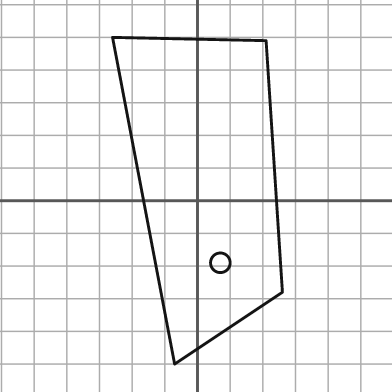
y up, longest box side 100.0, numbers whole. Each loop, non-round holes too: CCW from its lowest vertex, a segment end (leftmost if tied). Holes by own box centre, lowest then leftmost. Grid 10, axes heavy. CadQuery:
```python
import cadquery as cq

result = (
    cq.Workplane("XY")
    .moveTo(-7.0, -50.0)
    .lineTo(26.0, -28.0)
    .lineTo(21.0, 49.0)
    .lineTo(-26.0, 50.0)
    .close()
    .moveTo(7.0, -19.0)
    .circle(3.0)
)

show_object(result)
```